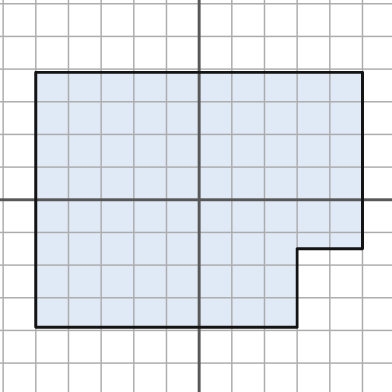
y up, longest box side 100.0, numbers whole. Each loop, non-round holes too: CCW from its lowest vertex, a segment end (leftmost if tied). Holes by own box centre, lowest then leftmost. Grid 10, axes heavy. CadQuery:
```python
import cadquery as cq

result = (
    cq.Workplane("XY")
    .moveTo(-50.0, -39.0)
    .lineTo(30.0, -39.0)
    .lineTo(30.0, -15.0)
    .lineTo(50.0, -15.0)
    .lineTo(50.0, 39.0)
    .lineTo(-50.0, 39.0)
    .close()
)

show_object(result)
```